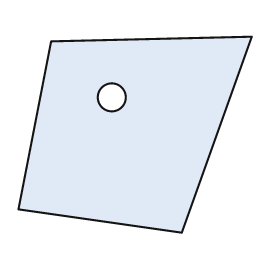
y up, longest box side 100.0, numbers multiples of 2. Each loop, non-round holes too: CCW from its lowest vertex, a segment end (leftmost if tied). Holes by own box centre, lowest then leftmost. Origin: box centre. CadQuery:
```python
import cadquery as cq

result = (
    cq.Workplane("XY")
    .moveTo(20.0, -42.0)
    .lineTo(50.0, 42.0)
    .lineTo(-36.0, 40.0)
    .lineTo(-50.0, -32.0)
    .close()
    .moveTo(-10.0, 16.0)
    .circle(6.0)
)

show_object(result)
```